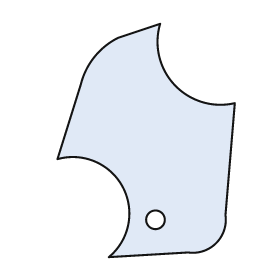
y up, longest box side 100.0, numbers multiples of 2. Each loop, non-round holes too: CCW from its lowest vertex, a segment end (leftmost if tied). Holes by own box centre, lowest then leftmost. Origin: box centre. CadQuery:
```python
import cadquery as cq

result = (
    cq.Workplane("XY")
    .moveTo(-16.0, -50.0)
    .lineTo(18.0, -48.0)
    .threePointArc((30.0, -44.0), (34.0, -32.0))
    .lineTo(38.0, 16.0)
    .threePointArc((12.0, 24.0), (6.0, 50.0))
    .lineTo(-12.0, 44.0)
    .threePointArc((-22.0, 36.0), (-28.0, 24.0))
    .lineTo(-38.0, -8.0)
    .threePointArc((-10.0, -20.0), (-16.0, -50.0))
    .close()
    .moveTo(4.0, -34.0)
    .circle(4.0)
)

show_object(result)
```